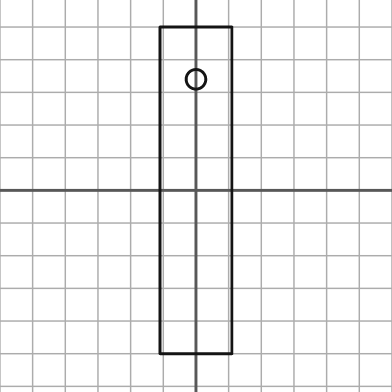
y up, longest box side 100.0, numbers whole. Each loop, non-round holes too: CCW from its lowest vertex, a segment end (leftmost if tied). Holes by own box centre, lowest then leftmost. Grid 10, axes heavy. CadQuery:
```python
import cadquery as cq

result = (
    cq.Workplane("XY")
    .moveTo(-11.0, -50.0)
    .lineTo(11.0, -50.0)
    .lineTo(11.0, 50.0)
    .lineTo(-11.0, 50.0)
    .close()
    .moveTo(0.0, 34.0)
    .circle(3.0)
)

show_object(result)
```